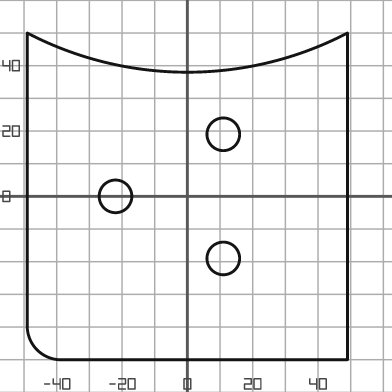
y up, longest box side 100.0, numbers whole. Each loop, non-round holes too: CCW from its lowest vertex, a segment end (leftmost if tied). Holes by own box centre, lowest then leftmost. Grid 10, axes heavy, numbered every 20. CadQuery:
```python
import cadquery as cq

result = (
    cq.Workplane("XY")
    .moveTo(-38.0, -50.0)
    .lineTo(49.0, -50.0)
    .lineTo(49.0, 50.0)
    .threePointArc((0.0, 38.0), (-49.0, 50.0))
    .lineTo(-49.0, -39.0)
    .threePointArc((-46.0, -47.0), (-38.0, -50.0))
    .close()
    .moveTo(11.0, -19.0)
    .circle(5.0)
    .moveTo(-22.0, 0.0)
    .circle(5.0)
    .moveTo(11.0, 19.0)
    .circle(5.0)
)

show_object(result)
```